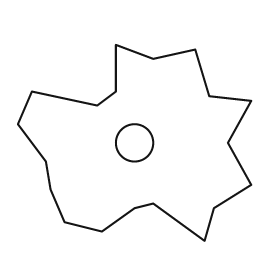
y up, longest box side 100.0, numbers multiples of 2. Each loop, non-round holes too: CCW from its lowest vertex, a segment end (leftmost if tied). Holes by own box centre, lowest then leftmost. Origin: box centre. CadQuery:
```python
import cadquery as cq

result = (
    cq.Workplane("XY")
    .moveTo(30.0, -42.0)
    .lineTo(34.0, -28.0)
    .lineTo(50.0, -18.0)
    .lineTo(40.0, 0.0)
    .lineTo(50.0, 18.0)
    .lineTo(32.0, 20.0)
    .lineTo(26.0, 40.0)
    .lineTo(8.0, 36.0)
    .lineTo(-8.0, 42.0)
    .lineTo(-8.0, 22.0)
    .lineTo(-16.0, 16.0)
    .lineTo(-44.0, 22.0)
    .lineTo(-50.0, 8.0)
    .lineTo(-38.0, -8.0)
    .lineTo(-36.0, -20.0)
    .lineTo(-30.0, -34.0)
    .lineTo(-14.0, -38.0)
    .lineTo(0.0, -28.0)
    .lineTo(8.0, -26.0)
    .close()
    .moveTo(0.0, 0.0)
    .circle(8.0)
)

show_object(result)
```